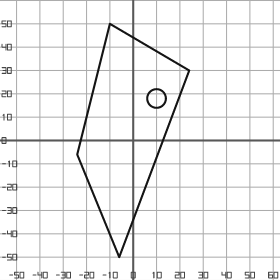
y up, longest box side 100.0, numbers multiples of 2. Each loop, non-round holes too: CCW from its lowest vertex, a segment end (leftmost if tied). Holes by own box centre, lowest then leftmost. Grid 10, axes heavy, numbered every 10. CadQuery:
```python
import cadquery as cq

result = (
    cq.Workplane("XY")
    .moveTo(-6.0, -50.0)
    .lineTo(24.0, 30.0)
    .lineTo(-10.0, 50.0)
    .lineTo(-24.0, -6.0)
    .close()
    .moveTo(10.0, 18.0)
    .circle(4.0)
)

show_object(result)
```